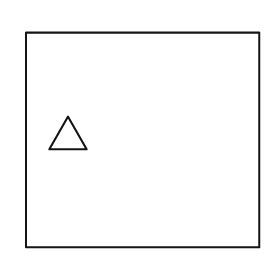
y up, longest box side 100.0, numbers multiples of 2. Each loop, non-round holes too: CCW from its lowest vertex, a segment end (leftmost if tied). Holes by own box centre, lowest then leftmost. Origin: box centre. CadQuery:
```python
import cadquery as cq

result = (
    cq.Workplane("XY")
    .moveTo(-50.0, -46.0)
    .lineTo(50.0, -46.0)
    .lineTo(50.0, 46.0)
    .lineTo(-50.0, 46.0)
    .close()
    .moveTo(-40.0, -4.0)
    .lineTo(-24.0, -4.0)
    .lineTo(-32.0, 10.0)
    .close()
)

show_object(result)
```